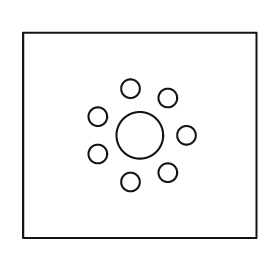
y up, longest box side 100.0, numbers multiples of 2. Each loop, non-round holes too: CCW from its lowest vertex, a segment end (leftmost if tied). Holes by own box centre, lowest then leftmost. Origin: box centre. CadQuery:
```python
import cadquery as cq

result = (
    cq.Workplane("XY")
    .moveTo(-50.0, -44.0)
    .lineTo(50.0, -44.0)
    .lineTo(50.0, 44.0)
    .lineTo(-50.0, 44.0)
    .close()
    .moveTo(-4.0, -20.0)
    .circle(4.0)
    .moveTo(12.0, -16.0)
    .circle(4.0)
    .moveTo(-18.0, -8.0)
    .circle(4.0)
    .moveTo(0.0, 0.0)
    .circle(10.0)
    .moveTo(20.0, 0.0)
    .circle(4.0)
    .moveTo(-18.0, 8.0)
    .circle(4.0)
    .moveTo(12.0, 16.0)
    .circle(4.0)
    .moveTo(-4.0, 20.0)
    .circle(4.0)
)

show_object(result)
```